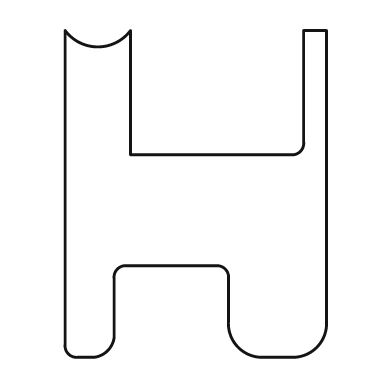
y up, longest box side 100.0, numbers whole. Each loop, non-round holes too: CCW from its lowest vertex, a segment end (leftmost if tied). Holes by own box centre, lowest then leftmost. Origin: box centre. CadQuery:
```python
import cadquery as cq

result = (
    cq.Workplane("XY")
    .moveTo(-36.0, -50.0)
    .lineTo(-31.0, -50.0)
    .threePointArc((-27.0, -48.0), (-25.0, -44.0))
    .lineTo(-25.0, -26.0)
    .threePointArc((-24.0, -23.0), (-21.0, -22.0))
    .lineTo(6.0, -22.0)
    .threePointArc((9.0, -23.0), (10.0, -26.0))
    .lineTo(10.0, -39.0)
    .threePointArc((13.0, -47.0), (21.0, -50.0))
    .lineTo(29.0, -50.0)
    .threePointArc((37.0, -47.0), (40.0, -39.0))
    .lineTo(40.0, 50.0)
    .lineTo(33.0, 50.0)
    .lineTo(33.0, 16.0)
    .threePointArc((32.0, 13.0), (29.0, 12.0))
    .lineTo(-20.0, 12.0)
    .lineTo(-20.0, 50.0)
    .threePointArc((-30.0, 45.0), (-40.0, 50.0))
    .lineTo(-40.0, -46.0)
    .threePointArc((-39.0, -49.0), (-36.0, -50.0))
    .close()
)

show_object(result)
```